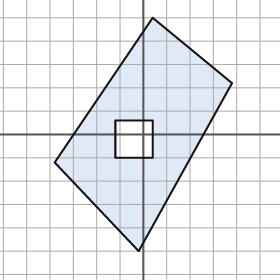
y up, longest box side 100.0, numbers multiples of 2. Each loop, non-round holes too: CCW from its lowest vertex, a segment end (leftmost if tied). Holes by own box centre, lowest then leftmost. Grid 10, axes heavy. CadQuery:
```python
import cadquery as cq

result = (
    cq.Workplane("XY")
    .moveTo(-2.0, -50.0)
    .lineTo(38.0, 22.0)
    .lineTo(4.0, 50.0)
    .lineTo(-38.0, -12.0)
    .close()
    .moveTo(-12.0, -10.0)
    .lineTo(4.0, -10.0)
    .lineTo(4.0, 6.0)
    .lineTo(-12.0, 6.0)
    .close()
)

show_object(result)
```